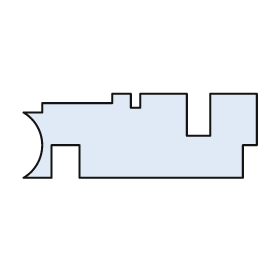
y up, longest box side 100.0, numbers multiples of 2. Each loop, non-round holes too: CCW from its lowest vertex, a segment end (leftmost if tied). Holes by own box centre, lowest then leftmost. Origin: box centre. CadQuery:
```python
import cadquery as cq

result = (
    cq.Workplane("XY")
    .moveTo(-50.0, -18.0)
    .lineTo(-38.0, -18.0)
    .lineTo(-38.0, -4.0)
    .lineTo(-26.0, -4.0)
    .lineTo(-26.0, -18.0)
    .lineTo(44.0, -18.0)
    .lineTo(44.0, -4.0)
    .lineTo(50.0, -4.0)
    .lineTo(50.0, 18.0)
    .lineTo(30.0, 18.0)
    .lineTo(30.0, 0.0)
    .lineTo(20.0, 0.0)
    .lineTo(20.0, 18.0)
    .lineTo(0.0, 18.0)
    .lineTo(0.0, 12.0)
    .lineTo(-4.0, 12.0)
    .lineTo(-4.0, 18.0)
    .lineTo(-12.0, 18.0)
    .lineTo(-12.0, 14.0)
    .lineTo(-42.0, 14.0)
    .lineTo(-42.0, 10.0)
    .lineTo(-50.0, 10.0)
    .threePointArc((-42.0, -4.0), (-50.0, -18.0))
    .close()
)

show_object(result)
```